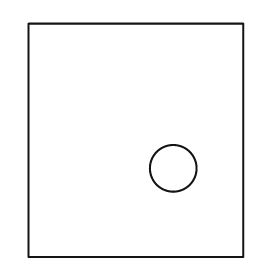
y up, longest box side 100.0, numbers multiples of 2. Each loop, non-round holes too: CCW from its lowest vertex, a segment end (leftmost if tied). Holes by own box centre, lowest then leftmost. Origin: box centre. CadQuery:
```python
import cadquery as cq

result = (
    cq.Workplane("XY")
    .moveTo(-46.0, -50.0)
    .lineTo(46.0, -50.0)
    .lineTo(46.0, 50.0)
    .lineTo(-46.0, 50.0)
    .close()
    .moveTo(16.0, -12.0)
    .circle(10.0)
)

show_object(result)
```